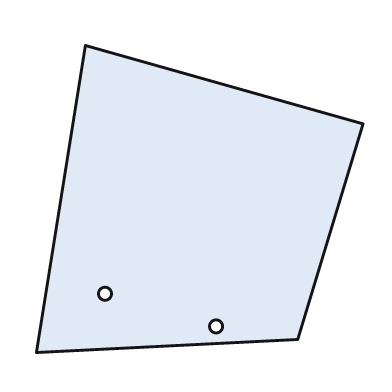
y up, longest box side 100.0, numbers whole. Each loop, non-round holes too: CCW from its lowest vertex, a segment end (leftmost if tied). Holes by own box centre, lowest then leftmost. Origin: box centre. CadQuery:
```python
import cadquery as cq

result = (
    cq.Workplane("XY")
    .moveTo(-50.0, -47.0)
    .lineTo(30.0, -43.0)
    .lineTo(50.0, 23.0)
    .lineTo(-35.0, 47.0)
    .close()
    .moveTo(5.0, -39.0)
    .circle(2.0)
    .moveTo(-29.0, -29.0)
    .circle(2.0)
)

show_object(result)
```